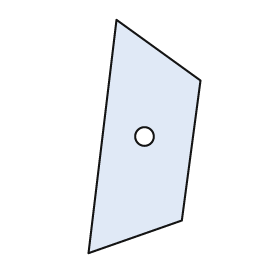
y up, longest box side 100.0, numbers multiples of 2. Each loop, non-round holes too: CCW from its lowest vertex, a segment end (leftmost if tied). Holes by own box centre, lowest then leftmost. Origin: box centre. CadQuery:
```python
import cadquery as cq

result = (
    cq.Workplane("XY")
    .moveTo(-24.0, -50.0)
    .lineTo(16.0, -36.0)
    .lineTo(24.0, 24.0)
    .lineTo(-12.0, 50.0)
    .close()
    .moveTo(0.0, 0.0)
    .circle(4.0)
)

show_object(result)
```